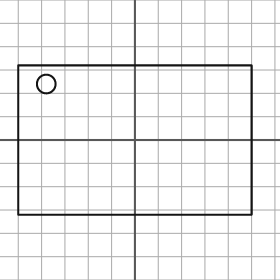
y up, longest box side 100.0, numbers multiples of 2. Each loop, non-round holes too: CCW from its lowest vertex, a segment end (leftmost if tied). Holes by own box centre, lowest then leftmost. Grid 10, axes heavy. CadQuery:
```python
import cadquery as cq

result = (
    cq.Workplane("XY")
    .moveTo(-50.0, -32.0)
    .lineTo(50.0, -32.0)
    .lineTo(50.0, 32.0)
    .lineTo(-50.0, 32.0)
    .close()
    .moveTo(-38.0, 24.0)
    .circle(4.0)
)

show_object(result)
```